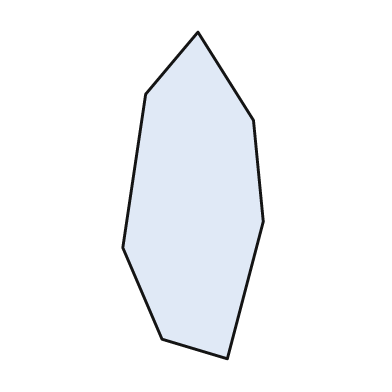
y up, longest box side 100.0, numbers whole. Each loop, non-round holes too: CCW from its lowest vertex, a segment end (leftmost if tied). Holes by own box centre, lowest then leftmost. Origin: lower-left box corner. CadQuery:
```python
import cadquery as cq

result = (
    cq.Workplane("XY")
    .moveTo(32.0, 0.0)
    .lineTo(43.0, 42.0)
    .lineTo(40.0, 73.0)
    .lineTo(23.0, 100.0)
    .lineTo(7.0, 81.0)
    .lineTo(0.0, 34.0)
    .lineTo(12.0, 6.0)
    .close()
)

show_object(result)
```